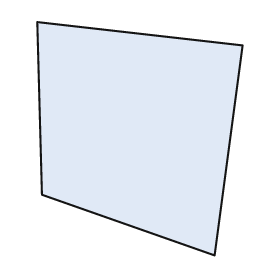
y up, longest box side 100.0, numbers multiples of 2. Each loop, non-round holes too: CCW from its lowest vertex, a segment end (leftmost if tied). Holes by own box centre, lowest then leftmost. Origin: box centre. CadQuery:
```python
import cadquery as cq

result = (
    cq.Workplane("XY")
    .moveTo(32.0, -50.0)
    .lineTo(44.0, 40.0)
    .lineTo(-44.0, 50.0)
    .lineTo(-42.0, -24.0)
    .close()
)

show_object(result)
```